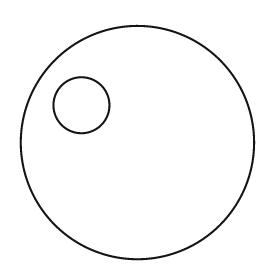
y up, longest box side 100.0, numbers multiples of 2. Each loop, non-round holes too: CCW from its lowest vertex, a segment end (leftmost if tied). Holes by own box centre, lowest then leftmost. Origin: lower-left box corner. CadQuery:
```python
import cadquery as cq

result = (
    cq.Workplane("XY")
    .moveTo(50.0, 50.0)
    .circle(50.0)
    .moveTo(26.0, 66.0)
    .circle(12.0)
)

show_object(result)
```